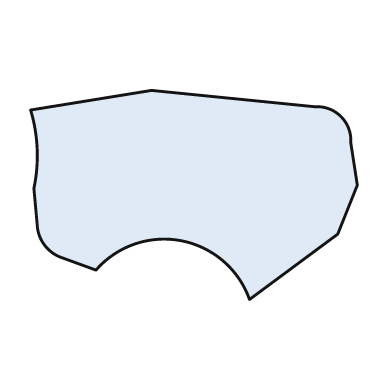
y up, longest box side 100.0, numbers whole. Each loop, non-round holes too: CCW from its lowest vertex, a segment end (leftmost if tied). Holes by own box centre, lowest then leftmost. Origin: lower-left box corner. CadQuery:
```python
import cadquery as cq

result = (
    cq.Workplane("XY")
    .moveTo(67.0, 0.0)
    .lineTo(94.0, 20.0)
    .lineTo(100.0, 35.0)
    .lineTo(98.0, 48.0)
    .threePointArc((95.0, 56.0), (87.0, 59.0))
    .lineTo(37.0, 64.0)
    .lineTo(0.0, 58.0)
    .threePointArc((2.0, 46.0), (1.0, 34.0))
    .lineTo(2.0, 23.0)
    .threePointArc((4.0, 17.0), (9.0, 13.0))
    .lineTo(20.0, 9.0)
    .threePointArc((46.0, 18.0), (67.0, 0.0))
    .close()
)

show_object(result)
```